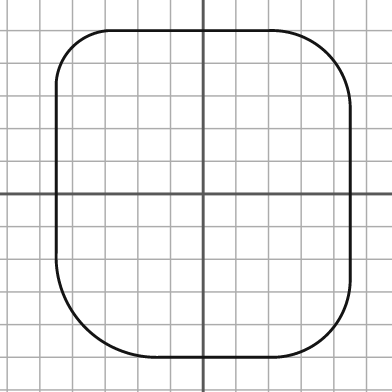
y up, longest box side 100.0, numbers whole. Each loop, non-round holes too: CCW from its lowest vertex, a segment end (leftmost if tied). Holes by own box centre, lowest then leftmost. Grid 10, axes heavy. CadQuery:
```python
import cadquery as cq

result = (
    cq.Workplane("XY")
    .moveTo(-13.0, -50.0)
    .lineTo(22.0, -50.0)
    .threePointArc((38.0, -43.0), (45.0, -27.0))
    .lineTo(45.0, 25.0)
    .threePointArc((38.0, 43.0), (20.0, 50.0))
    .lineTo(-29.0, 50.0)
    .threePointArc((-40.0, 45.0), (-45.0, 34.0))
    .lineTo(-45.0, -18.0)
    .threePointArc((-36.0, -41.0), (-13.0, -50.0))
    .close()
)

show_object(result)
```